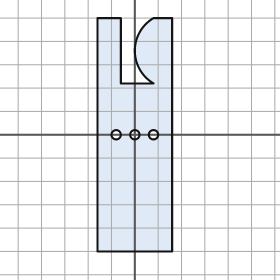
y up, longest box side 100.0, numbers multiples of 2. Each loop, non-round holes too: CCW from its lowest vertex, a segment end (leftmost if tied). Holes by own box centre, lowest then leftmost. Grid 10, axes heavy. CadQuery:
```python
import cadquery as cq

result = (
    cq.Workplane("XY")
    .moveTo(-16.0, -50.0)
    .lineTo(16.0, -50.0)
    .lineTo(16.0, 50.0)
    .lineTo(8.0, 50.0)
    .threePointArc((0.0, 36.0), (8.0, 22.0))
    .lineTo(-6.0, 22.0)
    .lineTo(-6.0, 50.0)
    .lineTo(-16.0, 50.0)
    .close()
    .moveTo(-8.0, 0.0)
    .circle(2.0)
    .moveTo(0.0, 0.0)
    .circle(2.0)
    .moveTo(8.0, 0.0)
    .circle(2.0)
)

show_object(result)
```